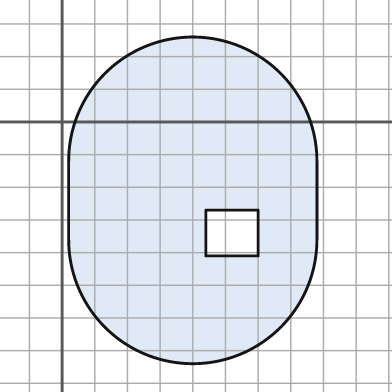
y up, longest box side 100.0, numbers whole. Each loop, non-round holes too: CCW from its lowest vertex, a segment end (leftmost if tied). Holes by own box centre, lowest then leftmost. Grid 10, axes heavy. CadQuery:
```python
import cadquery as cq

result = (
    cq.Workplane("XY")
    .moveTo(2.0, -36.0)
    .threePointArc((40.0, -74.0), (78.0, -36.0))
    .lineTo(78.0, -12.0)
    .threePointArc((40.0, 26.0), (2.0, -12.0))
    .close()
    .moveTo(44.0, -41.0)
    .lineTo(60.0, -41.0)
    .lineTo(60.0, -27.0)
    .lineTo(44.0, -27.0)
    .close()
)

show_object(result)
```